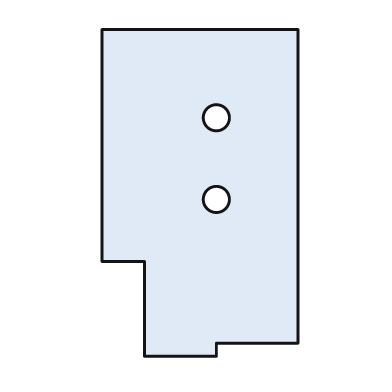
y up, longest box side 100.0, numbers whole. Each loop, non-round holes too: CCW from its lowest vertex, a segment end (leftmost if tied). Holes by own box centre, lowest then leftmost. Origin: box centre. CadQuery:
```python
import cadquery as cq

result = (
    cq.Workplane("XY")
    .moveTo(-17.0, -50.0)
    .lineTo(5.0, -50.0)
    .lineTo(5.0, -46.0)
    .lineTo(30.0, -46.0)
    .lineTo(30.0, 50.0)
    .lineTo(-30.0, 50.0)
    .lineTo(-30.0, -21.0)
    .lineTo(-17.0, -21.0)
    .close()
    .moveTo(5.0, -2.0)
    .circle(4.0)
    .moveTo(5.0, 23.0)
    .circle(4.0)
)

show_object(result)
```